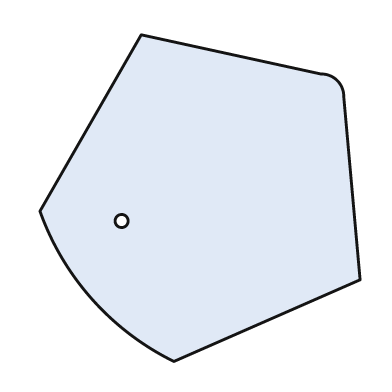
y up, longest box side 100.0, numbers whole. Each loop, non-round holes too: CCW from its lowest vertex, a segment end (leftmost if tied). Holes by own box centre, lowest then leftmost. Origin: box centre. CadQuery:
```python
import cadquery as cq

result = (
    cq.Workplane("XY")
    .moveTo(-8.0, -50.0)
    .lineTo(49.0, -25.0)
    .lineTo(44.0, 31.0)
    .threePointArc((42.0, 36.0), (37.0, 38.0))
    .lineTo(-18.0, 50.0)
    .lineTo(-49.0, -4.0)
    .threePointArc((-33.0, -31.0), (-8.0, -50.0))
    .close()
    .moveTo(-24.0, -7.0)
    .circle(2.0)
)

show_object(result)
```